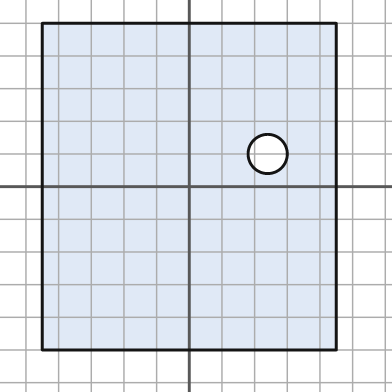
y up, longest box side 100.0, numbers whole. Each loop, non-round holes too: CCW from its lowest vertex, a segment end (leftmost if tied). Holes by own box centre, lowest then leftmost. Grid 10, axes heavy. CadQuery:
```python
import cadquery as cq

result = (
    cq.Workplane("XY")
    .moveTo(-45.0, -50.0)
    .lineTo(45.0, -50.0)
    .lineTo(45.0, 50.0)
    .lineTo(-45.0, 50.0)
    .close()
    .moveTo(24.0, 10.0)
    .circle(6.0)
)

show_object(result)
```